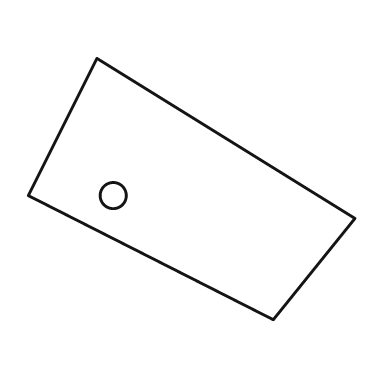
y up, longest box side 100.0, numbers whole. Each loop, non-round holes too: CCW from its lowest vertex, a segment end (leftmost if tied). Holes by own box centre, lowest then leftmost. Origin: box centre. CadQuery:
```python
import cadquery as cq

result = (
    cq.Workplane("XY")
    .moveTo(25.0, -40.0)
    .lineTo(50.0, -9.0)
    .lineTo(-29.0, 40.0)
    .lineTo(-50.0, -2.0)
    .close()
    .moveTo(-24.0, -2.0)
    .circle(4.0)
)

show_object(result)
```